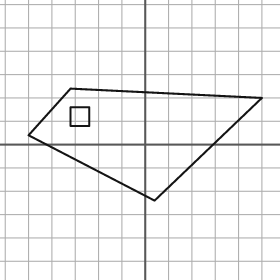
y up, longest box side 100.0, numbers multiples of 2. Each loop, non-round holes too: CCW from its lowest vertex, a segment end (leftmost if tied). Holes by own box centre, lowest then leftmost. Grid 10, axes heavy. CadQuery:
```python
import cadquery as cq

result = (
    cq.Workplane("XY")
    .moveTo(4.0, -24.0)
    .lineTo(50.0, 20.0)
    .lineTo(-32.0, 24.0)
    .lineTo(-50.0, 4.0)
    .close()
    .moveTo(-32.0, 8.0)
    .lineTo(-24.0, 8.0)
    .lineTo(-24.0, 16.0)
    .lineTo(-32.0, 16.0)
    .close()
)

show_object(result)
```